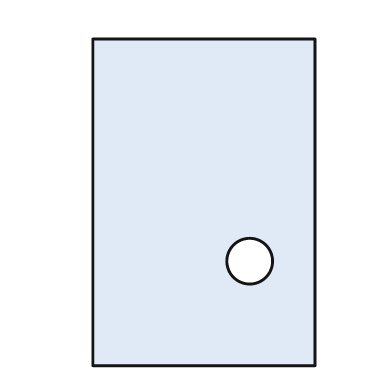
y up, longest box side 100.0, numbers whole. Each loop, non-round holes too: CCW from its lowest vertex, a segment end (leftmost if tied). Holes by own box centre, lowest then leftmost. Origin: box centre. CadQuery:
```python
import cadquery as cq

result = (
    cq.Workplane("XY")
    .moveTo(-34.0, -50.0)
    .lineTo(34.0, -50.0)
    .lineTo(34.0, 50.0)
    .lineTo(-34.0, 50.0)
    .close()
    .moveTo(14.0, -18.0)
    .circle(7.0)
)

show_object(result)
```